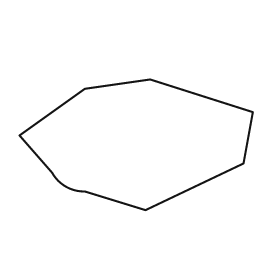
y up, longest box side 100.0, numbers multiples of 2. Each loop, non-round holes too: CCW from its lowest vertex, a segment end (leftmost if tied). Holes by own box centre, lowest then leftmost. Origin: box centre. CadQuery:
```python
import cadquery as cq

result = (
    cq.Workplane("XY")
    .moveTo(4.0, -28.0)
    .lineTo(46.0, -8.0)
    .lineTo(50.0, 14.0)
    .lineTo(6.0, 28.0)
    .lineTo(-22.0, 24.0)
    .lineTo(-50.0, 4.0)
    .lineTo(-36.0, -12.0)
    .threePointArc((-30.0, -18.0), (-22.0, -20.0))
    .close()
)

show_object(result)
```